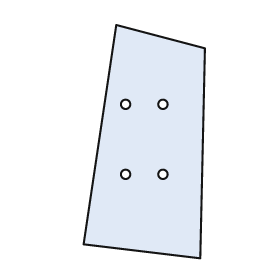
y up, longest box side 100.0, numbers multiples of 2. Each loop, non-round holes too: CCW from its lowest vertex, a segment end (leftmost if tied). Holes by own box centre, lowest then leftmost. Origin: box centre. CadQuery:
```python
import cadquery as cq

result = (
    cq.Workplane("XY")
    .moveTo(24.0, -50.0)
    .lineTo(26.0, 40.0)
    .lineTo(-12.0, 50.0)
    .lineTo(-26.0, -44.0)
    .close()
    .moveTo(-8.0, -14.0)
    .circle(2.0)
    .moveTo(8.0, -14.0)
    .circle(2.0)
    .moveTo(-8.0, 16.0)
    .circle(2.0)
    .moveTo(8.0, 16.0)
    .circle(2.0)
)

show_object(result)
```